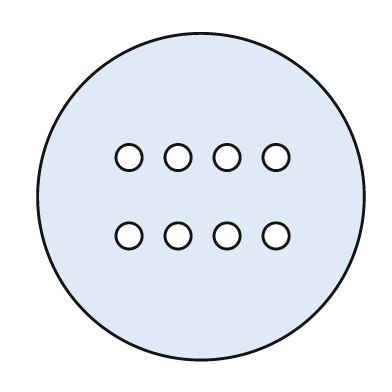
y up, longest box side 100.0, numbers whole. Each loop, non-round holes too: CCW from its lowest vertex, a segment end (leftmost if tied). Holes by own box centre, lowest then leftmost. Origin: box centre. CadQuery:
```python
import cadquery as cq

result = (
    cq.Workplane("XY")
    .moveTo(0.0, 0.0)
    .circle(50.0)
    .moveTo(-22.0, -12.0)
    .circle(4.0)
    .moveTo(-7.0, -12.0)
    .circle(4.0)
    .moveTo(8.0, -12.0)
    .circle(4.0)
    .moveTo(23.0, -12.0)
    .circle(4.0)
    .moveTo(-22.0, 12.0)
    .circle(4.0)
    .moveTo(-7.0, 12.0)
    .circle(4.0)
    .moveTo(8.0, 12.0)
    .circle(4.0)
    .moveTo(23.0, 12.0)
    .circle(4.0)
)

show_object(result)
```